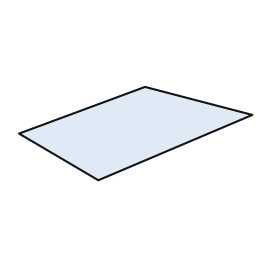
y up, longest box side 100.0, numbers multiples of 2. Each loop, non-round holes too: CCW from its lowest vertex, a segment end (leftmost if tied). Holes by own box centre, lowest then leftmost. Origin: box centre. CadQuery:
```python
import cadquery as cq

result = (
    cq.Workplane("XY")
    .moveTo(-16.0, -20.0)
    .lineTo(50.0, 8.0)
    .lineTo(4.0, 20.0)
    .lineTo(-50.0, 0.0)
    .close()
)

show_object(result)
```